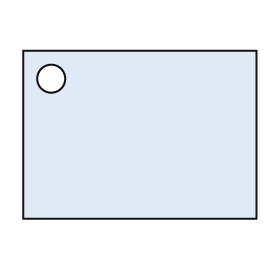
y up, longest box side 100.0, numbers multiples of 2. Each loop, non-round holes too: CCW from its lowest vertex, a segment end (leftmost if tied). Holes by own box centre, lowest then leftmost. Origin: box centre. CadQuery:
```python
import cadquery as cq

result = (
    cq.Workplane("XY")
    .moveTo(-50.0, -36.0)
    .lineTo(50.0, -36.0)
    .lineTo(50.0, 36.0)
    .lineTo(-50.0, 36.0)
    .close()
    .moveTo(-38.0, 24.0)
    .circle(6.0)
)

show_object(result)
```